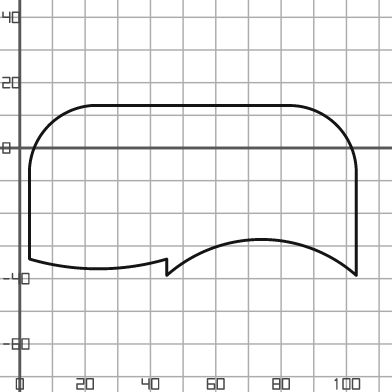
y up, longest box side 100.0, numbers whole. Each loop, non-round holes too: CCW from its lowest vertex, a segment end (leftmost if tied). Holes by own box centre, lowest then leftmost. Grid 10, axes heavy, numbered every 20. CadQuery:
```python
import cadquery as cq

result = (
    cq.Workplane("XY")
    .moveTo(45.0, -39.0)
    .threePointArc((74.0, -28.0), (103.0, -39.0))
    .lineTo(103.0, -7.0)
    .threePointArc((97.0, 7.0), (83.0, 13.0))
    .lineTo(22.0, 13.0)
    .threePointArc((9.0, 7.0), (3.0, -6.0))
    .lineTo(3.0, -34.0)
    .threePointArc((24.0, -37.0), (45.0, -34.0))
    .close()
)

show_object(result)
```